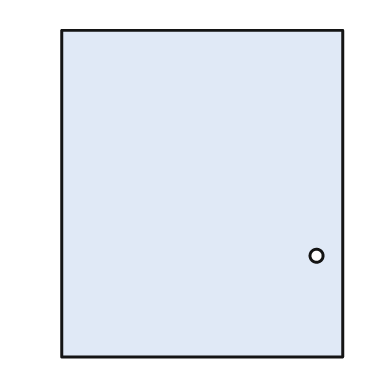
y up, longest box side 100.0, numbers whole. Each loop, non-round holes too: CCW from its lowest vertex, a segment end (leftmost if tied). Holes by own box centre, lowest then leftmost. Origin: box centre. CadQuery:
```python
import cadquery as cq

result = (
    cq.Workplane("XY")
    .moveTo(-43.0, -50.0)
    .lineTo(43.0, -50.0)
    .lineTo(43.0, 50.0)
    .lineTo(-43.0, 50.0)
    .close()
    .moveTo(35.0, -19.0)
    .circle(2.0)
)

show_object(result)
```